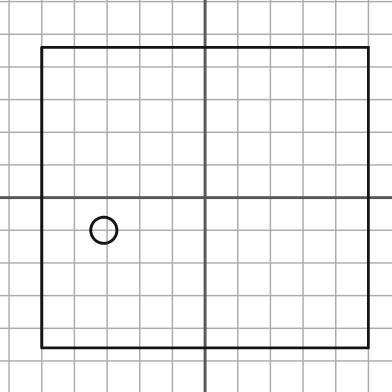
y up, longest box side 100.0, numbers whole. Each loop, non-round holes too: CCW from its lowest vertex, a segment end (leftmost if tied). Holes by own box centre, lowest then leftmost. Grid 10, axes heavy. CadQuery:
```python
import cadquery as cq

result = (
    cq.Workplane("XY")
    .moveTo(-50.0, -46.0)
    .lineTo(50.0, -46.0)
    .lineTo(50.0, 46.0)
    .lineTo(-50.0, 46.0)
    .close()
    .moveTo(-31.0, -10.0)
    .circle(4.0)
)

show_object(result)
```